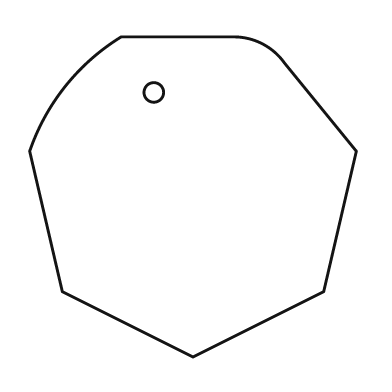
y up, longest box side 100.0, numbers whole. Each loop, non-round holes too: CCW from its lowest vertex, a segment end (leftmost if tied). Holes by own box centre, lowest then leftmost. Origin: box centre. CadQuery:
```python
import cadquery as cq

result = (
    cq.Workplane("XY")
    .moveTo(0.0, -49.0)
    .lineTo(40.0, -29.0)
    .lineTo(50.0, 14.0)
    .lineTo(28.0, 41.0)
    .threePointArc((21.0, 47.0), (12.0, 49.0))
    .lineTo(-22.0, 49.0)
    .threePointArc((-39.0, 34.0), (-50.0, 14.0))
    .lineTo(-40.0, -29.0)
    .close()
    .moveTo(-12.0, 32.0)
    .circle(3.0)
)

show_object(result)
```